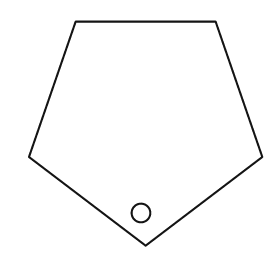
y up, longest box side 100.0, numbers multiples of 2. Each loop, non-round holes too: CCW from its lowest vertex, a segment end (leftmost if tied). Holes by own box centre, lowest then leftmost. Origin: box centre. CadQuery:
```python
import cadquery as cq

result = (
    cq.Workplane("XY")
    .moveTo(0.0, -48.0)
    .lineTo(50.0, -10.0)
    .lineTo(30.0, 48.0)
    .lineTo(-30.0, 48.0)
    .lineTo(-50.0, -10.0)
    .close()
    .moveTo(-2.0, -34.0)
    .circle(4.0)
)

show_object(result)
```